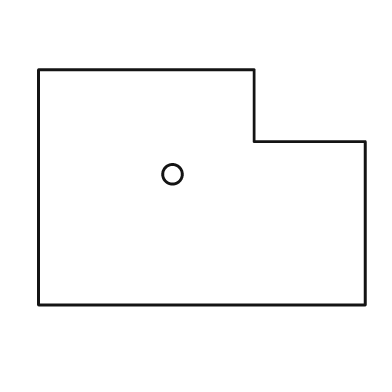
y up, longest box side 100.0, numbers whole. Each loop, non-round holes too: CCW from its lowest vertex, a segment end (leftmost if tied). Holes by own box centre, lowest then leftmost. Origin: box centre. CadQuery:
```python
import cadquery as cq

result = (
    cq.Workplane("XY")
    .moveTo(-50.0, -36.0)
    .lineTo(50.0, -36.0)
    .lineTo(50.0, 14.0)
    .lineTo(16.0, 14.0)
    .lineTo(16.0, 36.0)
    .lineTo(-50.0, 36.0)
    .close()
    .moveTo(-9.0, 4.0)
    .circle(3.0)
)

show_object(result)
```